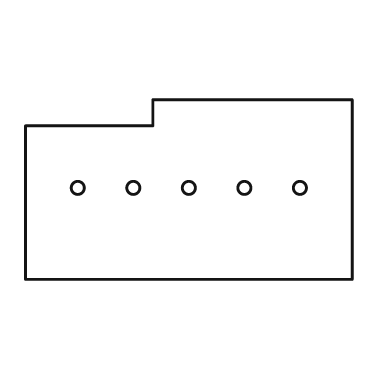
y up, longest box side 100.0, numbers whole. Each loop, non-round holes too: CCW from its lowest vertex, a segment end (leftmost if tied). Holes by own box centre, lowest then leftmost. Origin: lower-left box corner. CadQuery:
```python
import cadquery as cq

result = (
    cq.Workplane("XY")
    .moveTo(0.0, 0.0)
    .lineTo(100.0, 0.0)
    .lineTo(100.0, 55.0)
    .lineTo(39.0, 55.0)
    .lineTo(39.0, 47.0)
    .lineTo(0.0, 47.0)
    .close()
    .moveTo(16.0, 28.0)
    .circle(2.0)
    .moveTo(33.0, 28.0)
    .circle(2.0)
    .moveTo(50.0, 28.0)
    .circle(2.0)
    .moveTo(67.0, 28.0)
    .circle(2.0)
    .moveTo(84.0, 28.0)
    .circle(2.0)
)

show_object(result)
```